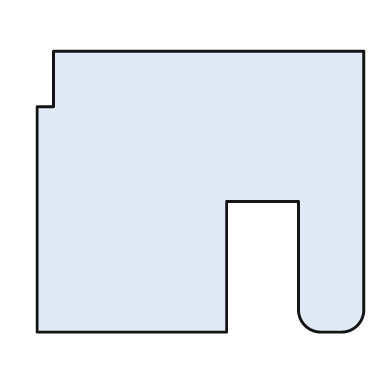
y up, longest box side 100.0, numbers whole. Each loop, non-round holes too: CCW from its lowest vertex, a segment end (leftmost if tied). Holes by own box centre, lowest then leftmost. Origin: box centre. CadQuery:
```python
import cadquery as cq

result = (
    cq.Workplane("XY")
    .moveTo(-50.0, -43.0)
    .lineTo(8.0, -43.0)
    .lineTo(8.0, -3.0)
    .lineTo(30.0, -3.0)
    .lineTo(30.0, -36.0)
    .threePointArc((32.0, -41.0), (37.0, -43.0))
    .lineTo(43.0, -43.0)
    .threePointArc((48.0, -41.0), (50.0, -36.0))
    .lineTo(50.0, 43.0)
    .lineTo(-45.0, 43.0)
    .lineTo(-45.0, 26.0)
    .lineTo(-50.0, 26.0)
    .close()
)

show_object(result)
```